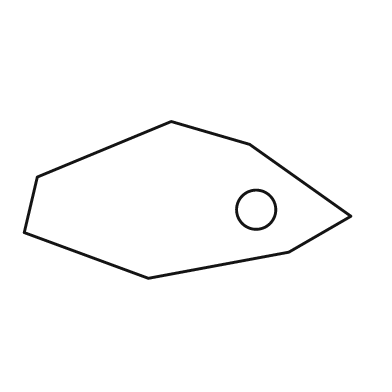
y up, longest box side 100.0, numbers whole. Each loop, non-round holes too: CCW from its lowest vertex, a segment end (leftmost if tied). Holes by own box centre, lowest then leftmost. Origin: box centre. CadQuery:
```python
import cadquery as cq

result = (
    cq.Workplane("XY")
    .moveTo(-12.0, -24.0)
    .lineTo(31.0, -16.0)
    .lineTo(50.0, -5.0)
    .lineTo(19.0, 17.0)
    .lineTo(-5.0, 24.0)
    .lineTo(-46.0, 7.0)
    .lineTo(-50.0, -10.0)
    .close()
    .moveTo(21.0, -3.0)
    .circle(6.0)
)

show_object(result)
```